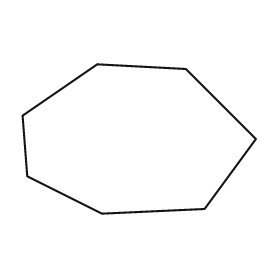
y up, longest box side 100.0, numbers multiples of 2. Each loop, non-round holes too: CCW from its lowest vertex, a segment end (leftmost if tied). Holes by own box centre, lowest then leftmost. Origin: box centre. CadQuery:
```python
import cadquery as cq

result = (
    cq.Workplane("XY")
    .moveTo(-16.0, -32.0)
    .lineTo(28.0, -30.0)
    .lineTo(50.0, 0.0)
    .lineTo(20.0, 30.0)
    .lineTo(-18.0, 32.0)
    .lineTo(-50.0, 10.0)
    .lineTo(-48.0, -16.0)
    .close()
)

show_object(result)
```